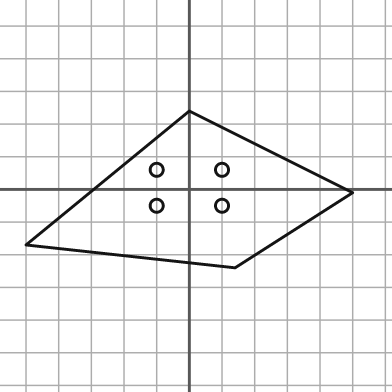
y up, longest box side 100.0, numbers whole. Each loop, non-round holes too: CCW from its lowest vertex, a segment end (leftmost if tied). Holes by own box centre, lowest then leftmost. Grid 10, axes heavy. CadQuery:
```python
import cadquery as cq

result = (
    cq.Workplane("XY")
    .moveTo(14.0, -24.0)
    .lineTo(50.0, -1.0)
    .lineTo(0.0, 24.0)
    .lineTo(-50.0, -17.0)
    .close()
    .moveTo(-10.0, -5.0)
    .circle(2.0)
    .moveTo(10.0, -5.0)
    .circle(2.0)
    .moveTo(-10.0, 6.0)
    .circle(2.0)
    .moveTo(10.0, 6.0)
    .circle(2.0)
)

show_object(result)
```